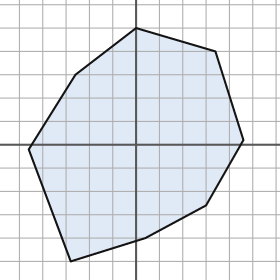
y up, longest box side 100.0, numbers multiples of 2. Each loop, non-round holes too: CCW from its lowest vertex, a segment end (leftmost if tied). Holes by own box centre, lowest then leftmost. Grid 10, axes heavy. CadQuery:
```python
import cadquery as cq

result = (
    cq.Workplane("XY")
    .moveTo(-28.0, -50.0)
    .lineTo(4.0, -40.0)
    .lineTo(30.0, -26.0)
    .lineTo(46.0, 2.0)
    .lineTo(34.0, 40.0)
    .lineTo(0.0, 50.0)
    .lineTo(-26.0, 30.0)
    .lineTo(-46.0, -2.0)
    .close()
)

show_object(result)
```